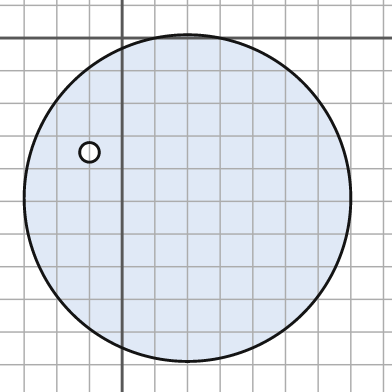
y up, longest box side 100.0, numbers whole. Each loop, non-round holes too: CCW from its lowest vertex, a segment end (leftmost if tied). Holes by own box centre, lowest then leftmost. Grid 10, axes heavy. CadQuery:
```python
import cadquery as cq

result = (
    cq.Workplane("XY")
    .moveTo(20.0, -49.0)
    .circle(50.0)
    .moveTo(-10.0, -35.0)
    .circle(3.0)
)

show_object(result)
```